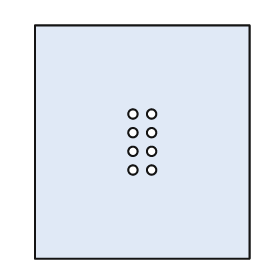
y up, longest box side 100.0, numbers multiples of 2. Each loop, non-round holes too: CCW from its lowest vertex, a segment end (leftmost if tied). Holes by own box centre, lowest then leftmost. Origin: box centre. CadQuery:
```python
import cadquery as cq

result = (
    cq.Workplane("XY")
    .moveTo(-46.0, -50.0)
    .lineTo(46.0, -50.0)
    .lineTo(46.0, 50.0)
    .lineTo(-46.0, 50.0)
    .close()
    .moveTo(-4.0, -12.0)
    .circle(2.0)
    .moveTo(4.0, -12.0)
    .circle(2.0)
    .moveTo(-4.0, -4.0)
    .circle(2.0)
    .moveTo(4.0, -4.0)
    .circle(2.0)
    .moveTo(-4.0, 4.0)
    .circle(2.0)
    .moveTo(4.0, 4.0)
    .circle(2.0)
    .moveTo(-4.0, 12.0)
    .circle(2.0)
    .moveTo(4.0, 12.0)
    .circle(2.0)
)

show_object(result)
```